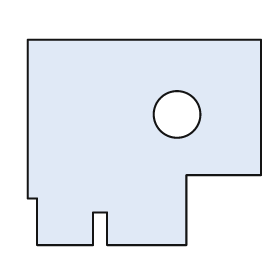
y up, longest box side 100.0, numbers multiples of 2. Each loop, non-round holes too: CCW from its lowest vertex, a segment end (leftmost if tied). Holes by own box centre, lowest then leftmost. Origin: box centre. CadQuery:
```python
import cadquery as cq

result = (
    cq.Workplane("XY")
    .moveTo(-46.0, -44.0)
    .lineTo(-22.0, -44.0)
    .lineTo(-22.0, -30.0)
    .lineTo(-16.0, -30.0)
    .lineTo(-16.0, -44.0)
    .lineTo(18.0, -44.0)
    .lineTo(18.0, -14.0)
    .lineTo(50.0, -14.0)
    .lineTo(50.0, 44.0)
    .lineTo(-50.0, 44.0)
    .lineTo(-50.0, -24.0)
    .lineTo(-46.0, -24.0)
    .close()
    .moveTo(14.0, 12.0)
    .circle(10.0)
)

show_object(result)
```